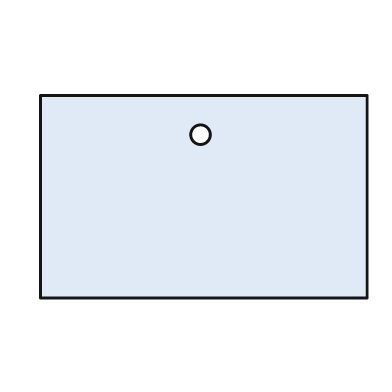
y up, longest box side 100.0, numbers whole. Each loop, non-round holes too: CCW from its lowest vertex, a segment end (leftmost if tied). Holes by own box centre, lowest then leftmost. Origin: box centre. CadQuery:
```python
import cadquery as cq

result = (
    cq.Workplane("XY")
    .moveTo(-50.0, -31.0)
    .lineTo(50.0, -31.0)
    .lineTo(50.0, 31.0)
    .lineTo(-50.0, 31.0)
    .close()
    .moveTo(-1.0, 19.0)
    .circle(3.0)
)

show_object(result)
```